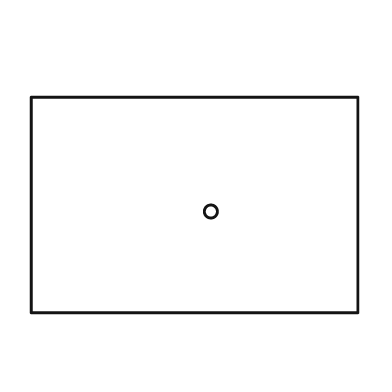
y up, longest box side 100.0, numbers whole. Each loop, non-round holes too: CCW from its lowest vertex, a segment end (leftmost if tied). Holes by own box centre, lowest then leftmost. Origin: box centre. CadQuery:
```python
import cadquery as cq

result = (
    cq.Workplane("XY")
    .moveTo(-50.0, -33.0)
    .lineTo(50.0, -33.0)
    .lineTo(50.0, 33.0)
    .lineTo(-50.0, 33.0)
    .close()
    .moveTo(5.0, -2.0)
    .circle(2.0)
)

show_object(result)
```